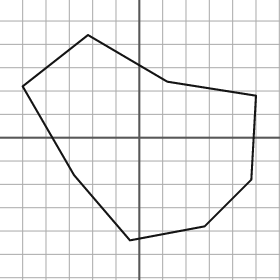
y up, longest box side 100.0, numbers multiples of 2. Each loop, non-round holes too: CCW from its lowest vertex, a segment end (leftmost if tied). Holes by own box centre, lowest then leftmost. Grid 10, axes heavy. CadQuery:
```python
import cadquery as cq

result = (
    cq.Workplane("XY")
    .moveTo(-4.0, -44.0)
    .lineTo(28.0, -38.0)
    .lineTo(48.0, -18.0)
    .lineTo(50.0, 18.0)
    .lineTo(12.0, 24.0)
    .lineTo(-22.0, 44.0)
    .lineTo(-50.0, 22.0)
    .lineTo(-28.0, -16.0)
    .close()
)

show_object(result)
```